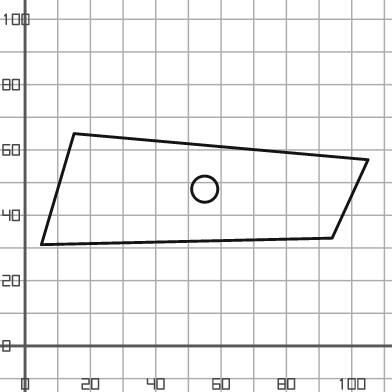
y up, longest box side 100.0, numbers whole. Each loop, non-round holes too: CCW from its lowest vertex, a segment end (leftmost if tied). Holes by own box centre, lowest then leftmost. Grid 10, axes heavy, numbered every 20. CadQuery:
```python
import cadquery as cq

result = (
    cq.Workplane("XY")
    .moveTo(5.0, 31.0)
    .lineTo(94.0, 33.0)
    .lineTo(105.0, 57.0)
    .lineTo(15.0, 65.0)
    .close()
    .moveTo(55.0, 48.0)
    .circle(4.0)
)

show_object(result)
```